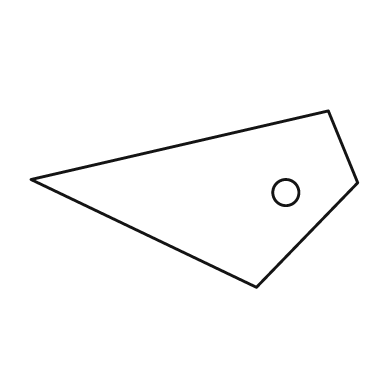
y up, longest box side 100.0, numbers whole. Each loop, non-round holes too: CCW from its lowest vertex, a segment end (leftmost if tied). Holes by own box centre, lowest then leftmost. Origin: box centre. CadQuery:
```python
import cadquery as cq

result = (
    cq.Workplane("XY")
    .moveTo(19.0, -27.0)
    .lineTo(50.0, 5.0)
    .lineTo(41.0, 27.0)
    .lineTo(-50.0, 6.0)
    .close()
    .moveTo(28.0, 2.0)
    .circle(4.0)
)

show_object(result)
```